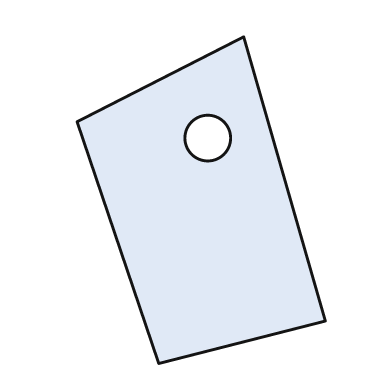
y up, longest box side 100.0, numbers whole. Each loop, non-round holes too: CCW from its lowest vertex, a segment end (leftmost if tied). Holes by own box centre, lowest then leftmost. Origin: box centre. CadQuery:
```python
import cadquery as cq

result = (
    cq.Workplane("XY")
    .moveTo(-13.0, -50.0)
    .lineTo(38.0, -37.0)
    .lineTo(13.0, 50.0)
    .lineTo(-38.0, 24.0)
    .close()
    .moveTo(2.0, 19.0)
    .circle(7.0)
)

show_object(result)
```